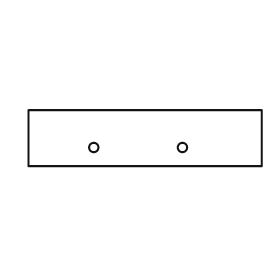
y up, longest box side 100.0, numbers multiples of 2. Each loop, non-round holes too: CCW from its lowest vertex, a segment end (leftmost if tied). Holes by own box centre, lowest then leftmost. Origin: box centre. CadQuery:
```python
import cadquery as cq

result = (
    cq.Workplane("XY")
    .moveTo(-50.0, -12.0)
    .lineTo(50.0, -12.0)
    .lineTo(50.0, 12.0)
    .lineTo(-50.0, 12.0)
    .close()
    .moveTo(-22.0, -4.0)
    .circle(2.0)
    .moveTo(16.0, -4.0)
    .circle(2.0)
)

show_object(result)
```